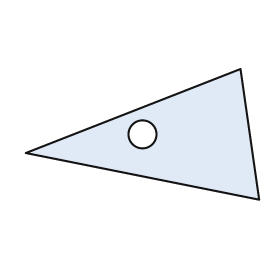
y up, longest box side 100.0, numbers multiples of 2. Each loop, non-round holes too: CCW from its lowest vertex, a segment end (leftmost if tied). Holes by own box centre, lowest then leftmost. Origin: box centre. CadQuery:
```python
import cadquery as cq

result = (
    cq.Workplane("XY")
    .moveTo(50.0, -28.0)
    .lineTo(42.0, 28.0)
    .lineTo(-50.0, -8.0)
    .close()
    .moveTo(0.0, 0.0)
    .circle(6.0)
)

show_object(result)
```